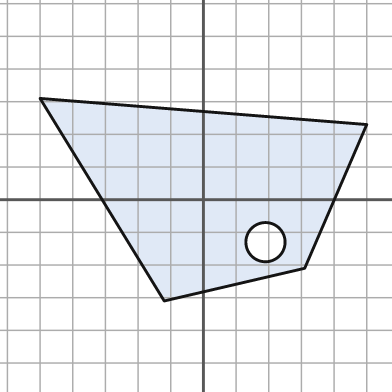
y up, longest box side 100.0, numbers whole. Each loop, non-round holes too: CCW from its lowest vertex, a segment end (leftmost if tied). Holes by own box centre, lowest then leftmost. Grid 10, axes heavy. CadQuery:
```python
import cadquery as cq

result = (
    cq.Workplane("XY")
    .moveTo(-12.0, -31.0)
    .lineTo(31.0, -21.0)
    .lineTo(50.0, 23.0)
    .lineTo(-50.0, 31.0)
    .close()
    .moveTo(19.0, -13.0)
    .circle(6.0)
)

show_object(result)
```